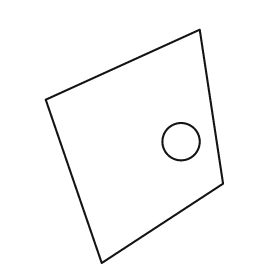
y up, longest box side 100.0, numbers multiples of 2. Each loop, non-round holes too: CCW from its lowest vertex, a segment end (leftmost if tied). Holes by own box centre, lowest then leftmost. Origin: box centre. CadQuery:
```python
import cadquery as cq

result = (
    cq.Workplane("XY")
    .moveTo(-14.0, -50.0)
    .lineTo(38.0, -16.0)
    .lineTo(28.0, 50.0)
    .lineTo(-38.0, 20.0)
    .close()
    .moveTo(20.0, 2.0)
    .circle(8.0)
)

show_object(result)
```